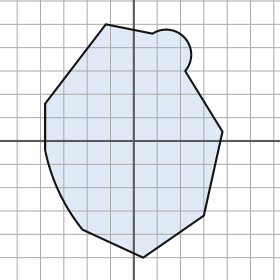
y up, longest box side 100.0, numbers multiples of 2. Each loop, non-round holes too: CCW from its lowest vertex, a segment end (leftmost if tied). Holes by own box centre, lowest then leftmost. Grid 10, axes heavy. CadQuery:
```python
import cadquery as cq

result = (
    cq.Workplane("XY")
    .moveTo(4.0, -50.0)
    .lineTo(30.0, -32.0)
    .lineTo(38.0, 4.0)
    .lineTo(22.0, 30.0)
    .threePointArc((22.0, 44.0), (8.0, 46.0))
    .lineTo(-12.0, 50.0)
    .lineTo(-38.0, 16.0)
    .lineTo(-38.0, -4.0)
    .threePointArc((-32.0, -22.0), (-22.0, -38.0))
    .close()
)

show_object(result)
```